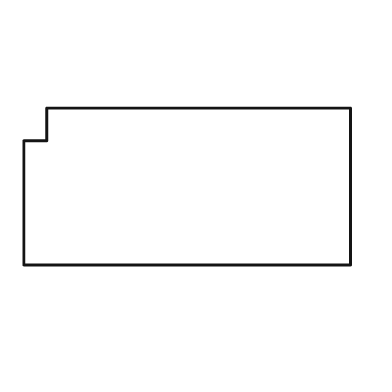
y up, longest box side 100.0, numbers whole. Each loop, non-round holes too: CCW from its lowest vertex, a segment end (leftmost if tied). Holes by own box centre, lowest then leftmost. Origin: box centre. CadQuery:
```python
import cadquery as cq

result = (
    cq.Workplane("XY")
    .moveTo(-50.0, -24.0)
    .lineTo(50.0, -24.0)
    .lineTo(50.0, 24.0)
    .lineTo(-43.0, 24.0)
    .lineTo(-43.0, 14.0)
    .lineTo(-50.0, 14.0)
    .close()
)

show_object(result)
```